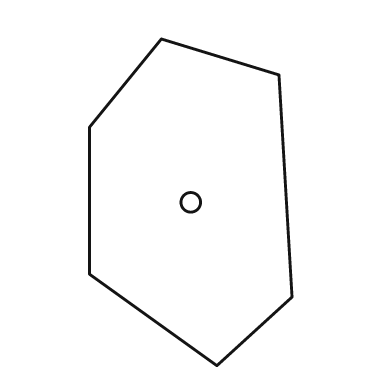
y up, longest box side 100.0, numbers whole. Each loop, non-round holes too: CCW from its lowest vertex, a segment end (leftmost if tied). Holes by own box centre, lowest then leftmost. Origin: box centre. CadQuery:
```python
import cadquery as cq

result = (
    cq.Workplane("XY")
    .moveTo(8.0, -50.0)
    .lineTo(31.0, -29.0)
    .lineTo(27.0, 39.0)
    .lineTo(-9.0, 50.0)
    .lineTo(-31.0, 23.0)
    .lineTo(-31.0, -22.0)
    .close()
    .moveTo(0.0, 0.0)
    .circle(3.0)
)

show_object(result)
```